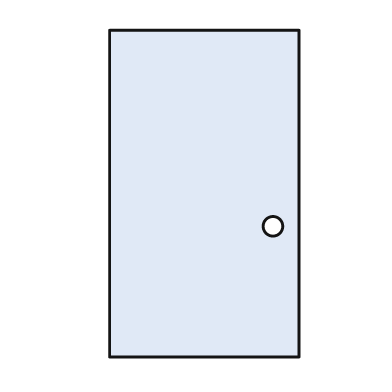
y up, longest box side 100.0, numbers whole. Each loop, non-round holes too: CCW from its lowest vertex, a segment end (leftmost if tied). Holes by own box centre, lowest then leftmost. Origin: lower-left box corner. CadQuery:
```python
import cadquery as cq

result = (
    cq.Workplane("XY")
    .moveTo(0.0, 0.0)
    .lineTo(58.0, 0.0)
    .lineTo(58.0, 100.0)
    .lineTo(0.0, 100.0)
    .close()
    .moveTo(50.0, 40.0)
    .circle(3.0)
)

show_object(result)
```